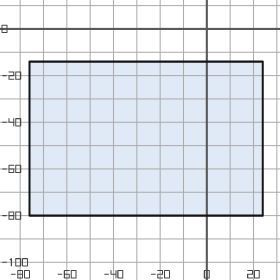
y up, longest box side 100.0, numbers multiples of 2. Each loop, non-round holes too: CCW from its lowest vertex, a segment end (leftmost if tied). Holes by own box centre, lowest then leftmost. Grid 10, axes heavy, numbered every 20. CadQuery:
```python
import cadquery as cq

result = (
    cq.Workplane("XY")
    .moveTo(-76.0, -80.0)
    .lineTo(24.0, -80.0)
    .lineTo(24.0, -14.0)
    .lineTo(-76.0, -14.0)
    .close()
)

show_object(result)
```